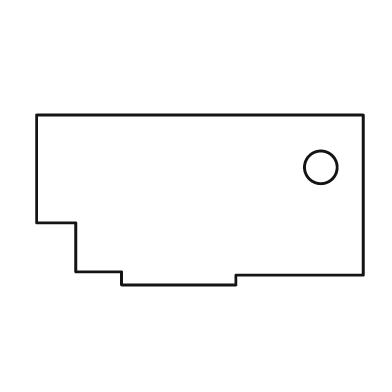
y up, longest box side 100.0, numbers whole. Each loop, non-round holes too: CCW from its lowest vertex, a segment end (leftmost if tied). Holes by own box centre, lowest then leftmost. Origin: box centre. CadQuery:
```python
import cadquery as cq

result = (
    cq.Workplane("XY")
    .moveTo(-24.0, -26.0)
    .lineTo(11.0, -26.0)
    .lineTo(11.0, -23.0)
    .lineTo(50.0, -23.0)
    .lineTo(50.0, 26.0)
    .lineTo(-50.0, 26.0)
    .lineTo(-50.0, -7.0)
    .lineTo(-38.0, -7.0)
    .lineTo(-38.0, -22.0)
    .lineTo(-24.0, -22.0)
    .close()
    .moveTo(37.0, 10.0)
    .circle(5.0)
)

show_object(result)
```